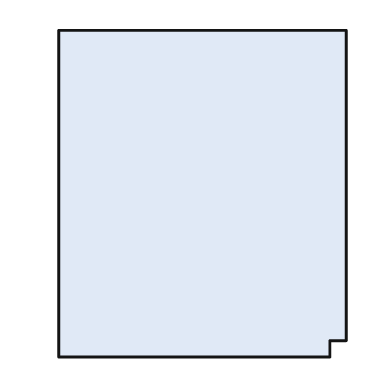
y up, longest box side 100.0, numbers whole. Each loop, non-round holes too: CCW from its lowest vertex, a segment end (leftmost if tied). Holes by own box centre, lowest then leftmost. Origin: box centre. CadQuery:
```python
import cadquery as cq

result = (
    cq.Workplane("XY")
    .moveTo(-44.0, -50.0)
    .lineTo(39.0, -50.0)
    .lineTo(39.0, -45.0)
    .lineTo(44.0, -45.0)
    .lineTo(44.0, 50.0)
    .lineTo(-44.0, 50.0)
    .close()
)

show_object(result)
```